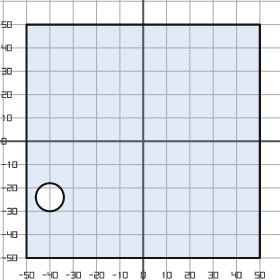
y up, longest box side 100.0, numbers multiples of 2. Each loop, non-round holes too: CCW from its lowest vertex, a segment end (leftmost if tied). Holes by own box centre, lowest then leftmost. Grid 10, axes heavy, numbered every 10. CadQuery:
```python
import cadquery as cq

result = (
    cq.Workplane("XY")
    .moveTo(-50.0, -50.0)
    .lineTo(50.0, -50.0)
    .lineTo(50.0, 50.0)
    .lineTo(-50.0, 50.0)
    .close()
    .moveTo(-40.0, -24.0)
    .circle(6.0)
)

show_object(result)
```